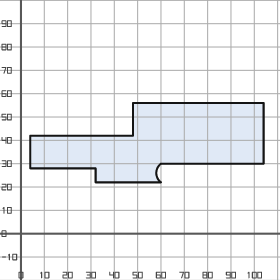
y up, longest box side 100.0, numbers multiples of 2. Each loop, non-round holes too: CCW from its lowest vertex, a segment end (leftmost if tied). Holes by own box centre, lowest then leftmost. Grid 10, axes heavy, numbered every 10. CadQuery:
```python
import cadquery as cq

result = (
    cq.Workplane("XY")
    .moveTo(32.0, 22.0)
    .lineTo(60.0, 22.0)
    .threePointArc((58.0, 26.0), (60.0, 30.0))
    .lineTo(104.0, 30.0)
    .lineTo(104.0, 56.0)
    .lineTo(48.0, 56.0)
    .lineTo(48.0, 42.0)
    .lineTo(4.0, 42.0)
    .lineTo(4.0, 28.0)
    .lineTo(32.0, 28.0)
    .close()
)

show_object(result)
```